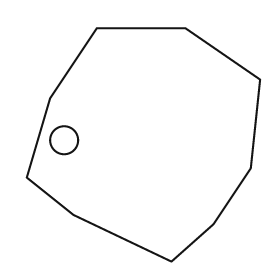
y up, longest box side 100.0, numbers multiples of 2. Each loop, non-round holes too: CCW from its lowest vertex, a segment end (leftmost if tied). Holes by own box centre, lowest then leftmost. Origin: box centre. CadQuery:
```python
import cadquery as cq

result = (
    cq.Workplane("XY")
    .moveTo(12.0, -50.0)
    .lineTo(30.0, -34.0)
    .lineTo(46.0, -10.0)
    .lineTo(50.0, 28.0)
    .lineTo(18.0, 50.0)
    .lineTo(-20.0, 50.0)
    .lineTo(-40.0, 20.0)
    .lineTo(-50.0, -14.0)
    .lineTo(-30.0, -30.0)
    .close()
    .moveTo(-34.0, 2.0)
    .circle(6.0)
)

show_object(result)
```